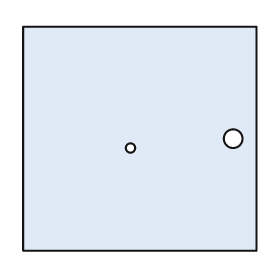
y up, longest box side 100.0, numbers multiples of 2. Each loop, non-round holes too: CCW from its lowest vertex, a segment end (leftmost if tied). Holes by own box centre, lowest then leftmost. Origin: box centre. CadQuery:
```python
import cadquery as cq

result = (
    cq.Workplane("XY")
    .moveTo(-50.0, -48.0)
    .lineTo(50.0, -48.0)
    .lineTo(50.0, 48.0)
    .lineTo(-50.0, 48.0)
    .close()
    .moveTo(-4.0, -4.0)
    .circle(2.0)
    .moveTo(40.0, 0.0)
    .circle(4.0)
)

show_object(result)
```